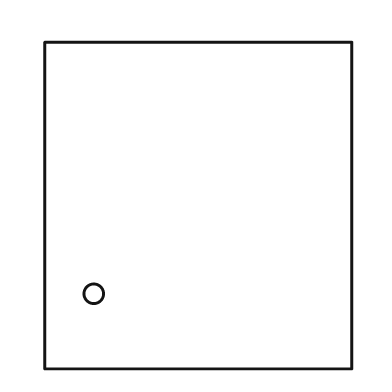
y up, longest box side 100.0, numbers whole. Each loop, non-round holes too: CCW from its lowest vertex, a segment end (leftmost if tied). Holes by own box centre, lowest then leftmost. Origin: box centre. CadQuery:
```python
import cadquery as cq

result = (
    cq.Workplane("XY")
    .moveTo(-47.0, -50.0)
    .lineTo(47.0, -50.0)
    .lineTo(47.0, 50.0)
    .lineTo(-47.0, 50.0)
    .close()
    .moveTo(-32.0, -27.0)
    .circle(3.0)
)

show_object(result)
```